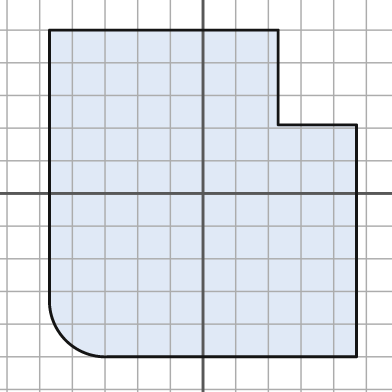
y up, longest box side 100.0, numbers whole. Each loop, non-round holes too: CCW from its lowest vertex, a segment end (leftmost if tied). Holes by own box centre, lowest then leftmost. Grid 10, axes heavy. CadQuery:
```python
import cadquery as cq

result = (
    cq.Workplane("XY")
    .moveTo(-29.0, -50.0)
    .lineTo(47.0, -50.0)
    .lineTo(47.0, 21.0)
    .lineTo(23.0, 21.0)
    .lineTo(23.0, 50.0)
    .lineTo(-47.0, 50.0)
    .lineTo(-47.0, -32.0)
    .threePointArc((-42.0, -45.0), (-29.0, -50.0))
    .close()
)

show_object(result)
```